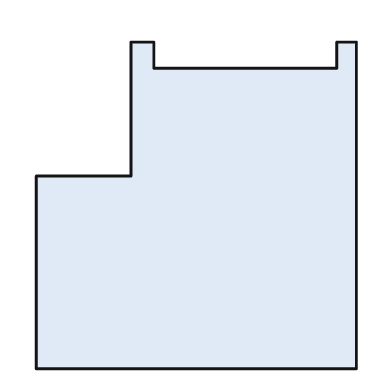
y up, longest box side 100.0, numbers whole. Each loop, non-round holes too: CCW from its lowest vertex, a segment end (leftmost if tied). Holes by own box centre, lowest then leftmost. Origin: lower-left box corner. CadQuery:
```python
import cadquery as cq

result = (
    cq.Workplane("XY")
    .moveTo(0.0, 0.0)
    .lineTo(98.0, 0.0)
    .lineTo(98.0, 100.0)
    .lineTo(92.0, 100.0)
    .lineTo(92.0, 92.0)
    .lineTo(36.0, 92.0)
    .lineTo(36.0, 100.0)
    .lineTo(29.0, 100.0)
    .lineTo(29.0, 59.0)
    .lineTo(0.0, 59.0)
    .close()
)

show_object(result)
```